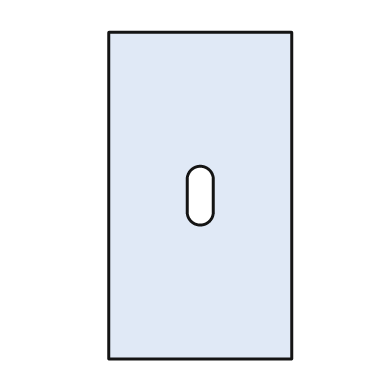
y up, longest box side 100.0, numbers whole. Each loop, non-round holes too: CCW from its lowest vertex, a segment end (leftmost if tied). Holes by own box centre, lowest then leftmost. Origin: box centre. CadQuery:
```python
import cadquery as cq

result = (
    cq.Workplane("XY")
    .moveTo(-28.0, -50.0)
    .lineTo(28.0, -50.0)
    .lineTo(28.0, 50.0)
    .lineTo(-28.0, 50.0)
    .close()
    .moveTo(-4.0, -5.0)
    .threePointArc((0.0, -9.0), (4.0, -5.0))
    .lineTo(4.0, 5.0)
    .threePointArc((0.0, 9.0), (-4.0, 5.0))
    .close()
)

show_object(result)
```